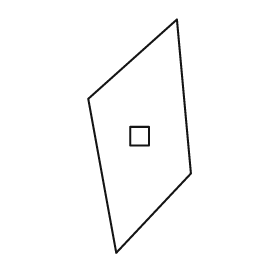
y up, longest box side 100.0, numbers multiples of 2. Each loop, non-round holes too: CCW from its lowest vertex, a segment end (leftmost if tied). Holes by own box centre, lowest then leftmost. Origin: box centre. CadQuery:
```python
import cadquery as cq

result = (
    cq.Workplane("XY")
    .moveTo(-10.0, -50.0)
    .lineTo(22.0, -16.0)
    .lineTo(16.0, 50.0)
    .lineTo(-22.0, 16.0)
    .close()
    .moveTo(-4.0, -4.0)
    .lineTo(4.0, -4.0)
    .lineTo(4.0, 4.0)
    .lineTo(-4.0, 4.0)
    .close()
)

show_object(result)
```